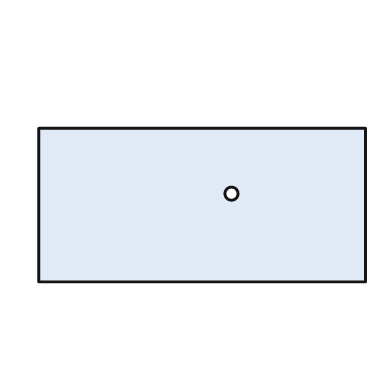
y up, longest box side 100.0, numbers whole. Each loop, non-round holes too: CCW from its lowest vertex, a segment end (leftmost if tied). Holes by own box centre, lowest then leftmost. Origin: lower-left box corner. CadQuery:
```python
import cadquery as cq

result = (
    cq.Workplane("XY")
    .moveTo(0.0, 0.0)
    .lineTo(100.0, 0.0)
    .lineTo(100.0, 47.0)
    .lineTo(0.0, 47.0)
    .close()
    .moveTo(59.0, 27.0)
    .circle(2.0)
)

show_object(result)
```